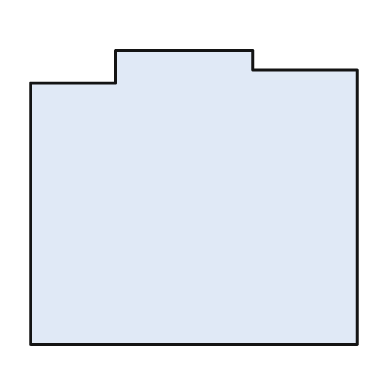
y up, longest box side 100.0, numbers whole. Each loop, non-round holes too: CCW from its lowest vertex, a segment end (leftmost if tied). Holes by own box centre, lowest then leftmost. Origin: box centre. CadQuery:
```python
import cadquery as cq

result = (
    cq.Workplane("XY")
    .moveTo(-50.0, -45.0)
    .lineTo(50.0, -45.0)
    .lineTo(50.0, 39.0)
    .lineTo(18.0, 39.0)
    .lineTo(18.0, 45.0)
    .lineTo(-24.0, 45.0)
    .lineTo(-24.0, 35.0)
    .lineTo(-50.0, 35.0)
    .close()
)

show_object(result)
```